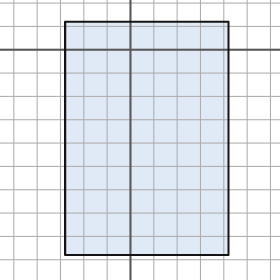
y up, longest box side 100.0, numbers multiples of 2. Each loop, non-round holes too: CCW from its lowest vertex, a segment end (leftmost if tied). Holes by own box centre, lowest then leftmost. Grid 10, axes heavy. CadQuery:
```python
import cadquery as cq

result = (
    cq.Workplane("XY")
    .moveTo(-28.0, -88.0)
    .lineTo(42.0, -88.0)
    .lineTo(42.0, 12.0)
    .lineTo(-28.0, 12.0)
    .close()
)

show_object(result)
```